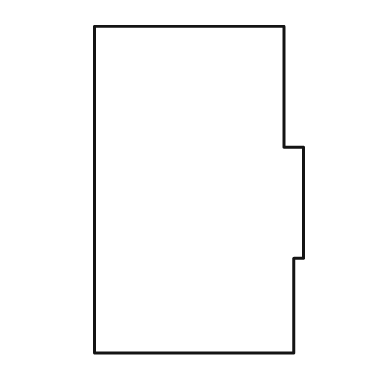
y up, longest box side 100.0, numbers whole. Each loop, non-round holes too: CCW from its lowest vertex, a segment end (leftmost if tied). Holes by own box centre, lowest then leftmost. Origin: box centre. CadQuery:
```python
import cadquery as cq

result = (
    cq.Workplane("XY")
    .moveTo(-32.0, -50.0)
    .lineTo(29.0, -50.0)
    .lineTo(29.0, -21.0)
    .lineTo(32.0, -21.0)
    .lineTo(32.0, 13.0)
    .lineTo(26.0, 13.0)
    .lineTo(26.0, 50.0)
    .lineTo(-32.0, 50.0)
    .close()
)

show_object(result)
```